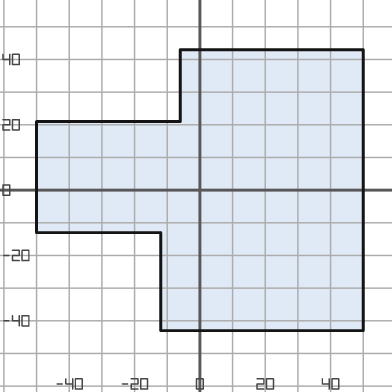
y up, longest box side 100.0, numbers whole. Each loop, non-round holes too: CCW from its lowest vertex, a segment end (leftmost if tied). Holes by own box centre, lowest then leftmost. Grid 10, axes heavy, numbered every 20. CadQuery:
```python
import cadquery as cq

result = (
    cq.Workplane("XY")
    .moveTo(-12.0, -43.0)
    .lineTo(50.0, -43.0)
    .lineTo(50.0, 43.0)
    .lineTo(-6.0, 43.0)
    .lineTo(-6.0, 21.0)
    .lineTo(-50.0, 21.0)
    .lineTo(-50.0, -13.0)
    .lineTo(-12.0, -13.0)
    .close()
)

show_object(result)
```